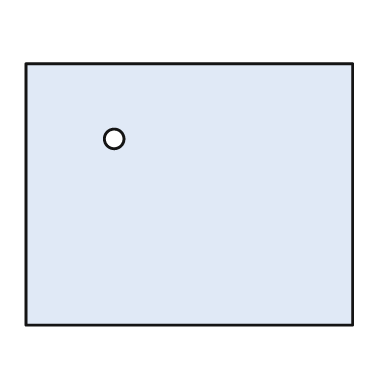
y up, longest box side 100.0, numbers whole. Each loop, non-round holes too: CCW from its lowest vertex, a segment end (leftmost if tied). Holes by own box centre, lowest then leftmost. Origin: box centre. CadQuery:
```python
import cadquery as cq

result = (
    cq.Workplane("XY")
    .moveTo(-50.0, -40.0)
    .lineTo(50.0, -40.0)
    .lineTo(50.0, 40.0)
    .lineTo(-50.0, 40.0)
    .close()
    .moveTo(-23.0, 17.0)
    .circle(3.0)
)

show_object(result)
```